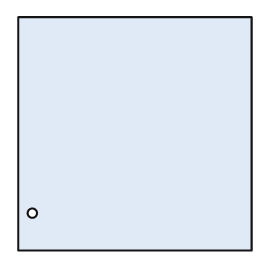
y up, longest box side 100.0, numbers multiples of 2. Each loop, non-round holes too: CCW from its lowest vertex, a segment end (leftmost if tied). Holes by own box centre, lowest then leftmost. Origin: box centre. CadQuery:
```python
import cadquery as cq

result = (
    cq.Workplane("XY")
    .moveTo(-50.0, -50.0)
    .lineTo(50.0, -50.0)
    .lineTo(50.0, 50.0)
    .lineTo(-50.0, 50.0)
    .close()
    .moveTo(-44.0, -34.0)
    .circle(2.0)
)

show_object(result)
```